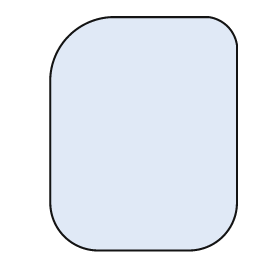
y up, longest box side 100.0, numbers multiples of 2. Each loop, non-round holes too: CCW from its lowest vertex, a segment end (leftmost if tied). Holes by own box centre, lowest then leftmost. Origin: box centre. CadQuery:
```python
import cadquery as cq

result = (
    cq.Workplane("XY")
    .moveTo(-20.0, -50.0)
    .lineTo(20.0, -50.0)
    .threePointArc((34.0, -44.0), (40.0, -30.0))
    .lineTo(40.0, 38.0)
    .threePointArc((36.0, 46.0), (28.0, 50.0))
    .lineTo(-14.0, 50.0)
    .threePointArc((-32.0, 42.0), (-40.0, 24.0))
    .lineTo(-40.0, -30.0)
    .threePointArc((-34.0, -44.0), (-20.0, -50.0))
    .close()
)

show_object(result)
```